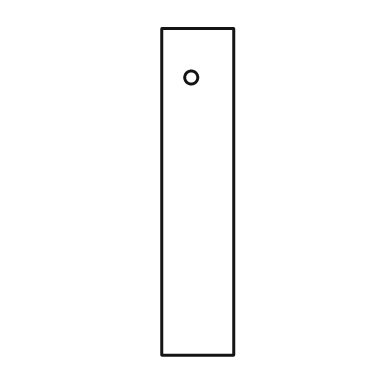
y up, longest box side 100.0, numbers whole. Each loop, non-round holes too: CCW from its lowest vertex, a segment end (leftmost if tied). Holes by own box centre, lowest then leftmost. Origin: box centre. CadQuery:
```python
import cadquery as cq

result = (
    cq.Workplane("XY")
    .moveTo(-11.0, -50.0)
    .lineTo(11.0, -50.0)
    .lineTo(11.0, 50.0)
    .lineTo(-11.0, 50.0)
    .close()
    .moveTo(-2.0, 35.0)
    .circle(2.0)
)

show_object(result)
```